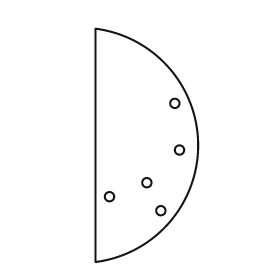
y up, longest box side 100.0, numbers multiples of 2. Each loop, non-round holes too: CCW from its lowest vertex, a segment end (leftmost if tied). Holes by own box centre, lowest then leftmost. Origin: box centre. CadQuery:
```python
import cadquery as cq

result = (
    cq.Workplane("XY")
    .moveTo(-22.0, -50.0)
    .threePointArc((22.0, 0.0), (-22.0, 50.0))
    .close()
    .moveTo(6.0, -28.0)
    .circle(2.0)
    .moveTo(-16.0, -22.0)
    .circle(2.0)
    .moveTo(0.0, -16.0)
    .circle(2.0)
    .moveTo(14.0, -2.0)
    .circle(2.0)
    .moveTo(12.0, 18.0)
    .circle(2.0)
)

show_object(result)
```